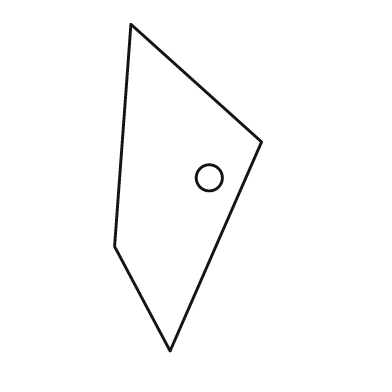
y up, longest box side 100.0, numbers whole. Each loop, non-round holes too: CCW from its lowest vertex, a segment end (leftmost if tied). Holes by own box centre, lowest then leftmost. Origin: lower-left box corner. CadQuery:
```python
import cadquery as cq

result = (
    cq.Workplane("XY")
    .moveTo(17.0, 0.0)
    .lineTo(45.0, 64.0)
    .lineTo(5.0, 100.0)
    .lineTo(0.0, 32.0)
    .close()
    .moveTo(29.0, 53.0)
    .circle(4.0)
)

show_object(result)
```